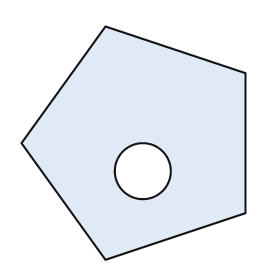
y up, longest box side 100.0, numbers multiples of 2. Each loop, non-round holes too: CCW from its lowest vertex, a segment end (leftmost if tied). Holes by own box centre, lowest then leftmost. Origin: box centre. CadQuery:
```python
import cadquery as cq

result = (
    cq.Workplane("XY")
    .moveTo(-12.0, -50.0)
    .lineTo(48.0, -30.0)
    .lineTo(48.0, 30.0)
    .lineTo(-12.0, 50.0)
    .lineTo(-48.0, 0.0)
    .close()
    .moveTo(4.0, -12.0)
    .circle(12.0)
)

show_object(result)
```